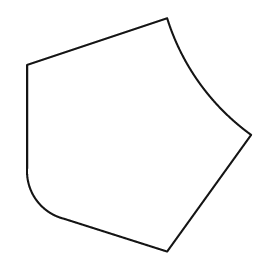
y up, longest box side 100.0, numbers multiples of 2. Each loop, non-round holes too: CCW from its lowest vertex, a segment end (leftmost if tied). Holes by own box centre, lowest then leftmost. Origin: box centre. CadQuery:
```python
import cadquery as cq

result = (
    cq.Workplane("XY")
    .moveTo(12.0, -50.0)
    .lineTo(48.0, 0.0)
    .threePointArc((26.0, 22.0), (12.0, 50.0))
    .lineTo(-48.0, 30.0)
    .lineTo(-48.0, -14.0)
    .threePointArc((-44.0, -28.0), (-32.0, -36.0))
    .close()
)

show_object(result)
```